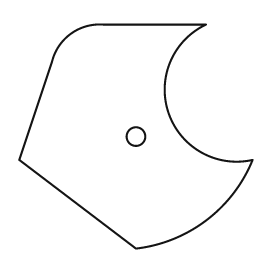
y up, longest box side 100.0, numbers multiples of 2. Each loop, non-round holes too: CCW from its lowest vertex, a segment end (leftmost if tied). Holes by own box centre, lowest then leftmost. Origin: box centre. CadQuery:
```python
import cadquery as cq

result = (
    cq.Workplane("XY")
    .moveTo(0.0, -48.0)
    .threePointArc((30.0, -36.0), (50.0, -10.0))
    .threePointArc((14.0, 10.0), (30.0, 48.0))
    .lineTo(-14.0, 48.0)
    .threePointArc((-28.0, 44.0), (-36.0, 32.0))
    .lineTo(-50.0, -10.0)
    .close()
    .moveTo(0.0, 0.0)
    .circle(4.0)
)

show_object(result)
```